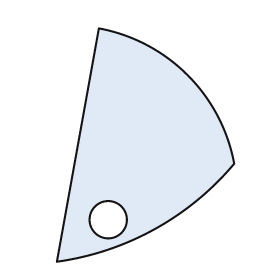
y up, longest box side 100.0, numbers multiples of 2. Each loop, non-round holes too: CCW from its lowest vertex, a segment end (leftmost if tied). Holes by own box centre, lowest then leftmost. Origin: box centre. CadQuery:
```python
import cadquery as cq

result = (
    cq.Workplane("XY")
    .moveTo(-38.0, -50.0)
    .threePointArc((4.0, -36.0), (38.0, -8.0))
    .threePointArc((18.0, 30.0), (-20.0, 50.0))
    .close()
    .moveTo(-16.0, -32.0)
    .circle(8.0)
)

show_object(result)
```